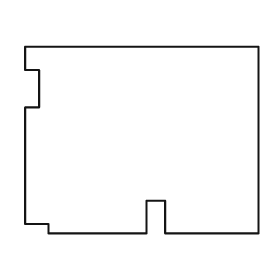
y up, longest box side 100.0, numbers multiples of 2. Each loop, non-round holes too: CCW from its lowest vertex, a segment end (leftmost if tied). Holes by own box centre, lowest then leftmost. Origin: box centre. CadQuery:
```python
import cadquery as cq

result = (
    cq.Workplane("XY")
    .moveTo(-40.0, -40.0)
    .lineTo(2.0, -40.0)
    .lineTo(2.0, -26.0)
    .lineTo(10.0, -26.0)
    .lineTo(10.0, -40.0)
    .lineTo(50.0, -40.0)
    .lineTo(50.0, 40.0)
    .lineTo(-50.0, 40.0)
    .lineTo(-50.0, 30.0)
    .lineTo(-44.0, 30.0)
    .lineTo(-44.0, 14.0)
    .lineTo(-50.0, 14.0)
    .lineTo(-50.0, -36.0)
    .lineTo(-40.0, -36.0)
    .close()
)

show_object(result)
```